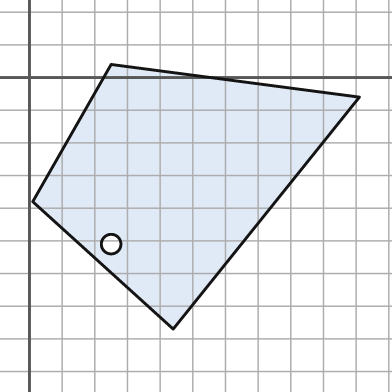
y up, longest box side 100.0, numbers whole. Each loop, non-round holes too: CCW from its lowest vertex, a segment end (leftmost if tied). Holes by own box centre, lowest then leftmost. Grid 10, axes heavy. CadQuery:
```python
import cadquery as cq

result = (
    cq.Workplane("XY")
    .moveTo(44.0, -77.0)
    .lineTo(101.0, -6.0)
    .lineTo(25.0, 4.0)
    .lineTo(1.0, -38.0)
    .close()
    .moveTo(25.0, -51.0)
    .circle(3.0)
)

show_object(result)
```